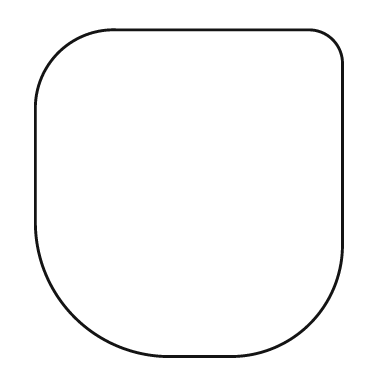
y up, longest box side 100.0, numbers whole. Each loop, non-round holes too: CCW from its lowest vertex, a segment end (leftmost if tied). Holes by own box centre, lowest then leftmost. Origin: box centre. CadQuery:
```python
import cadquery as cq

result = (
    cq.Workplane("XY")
    .moveTo(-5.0, -50.0)
    .lineTo(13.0, -50.0)
    .threePointArc((37.0, -40.0), (47.0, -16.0))
    .lineTo(47.0, 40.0)
    .threePointArc((44.0, 47.0), (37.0, 50.0))
    .lineTo(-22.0, 50.0)
    .threePointArc((-40.0, 43.0), (-47.0, 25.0))
    .lineTo(-47.0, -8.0)
    .threePointArc((-35.0, -38.0), (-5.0, -50.0))
    .close()
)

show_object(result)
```